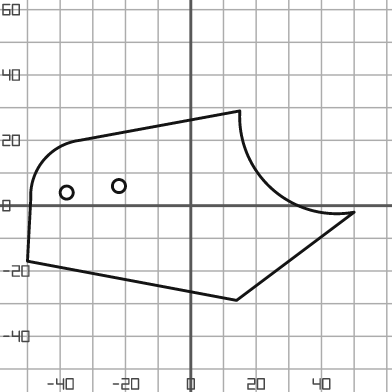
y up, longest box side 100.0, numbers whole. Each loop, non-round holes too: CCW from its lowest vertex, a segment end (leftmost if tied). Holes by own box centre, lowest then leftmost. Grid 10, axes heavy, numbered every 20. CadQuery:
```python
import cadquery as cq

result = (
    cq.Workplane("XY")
    .moveTo(14.0, -29.0)
    .lineTo(50.0, -2.0)
    .threePointArc((25.0, 5.0), (15.0, 29.0))
    .lineTo(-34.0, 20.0)
    .threePointArc((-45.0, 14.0), (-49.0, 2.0))
    .lineTo(-50.0, -17.0)
    .close()
    .moveTo(-38.0, 4.0)
    .circle(2.0)
    .moveTo(-22.0, 6.0)
    .circle(2.0)
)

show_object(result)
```